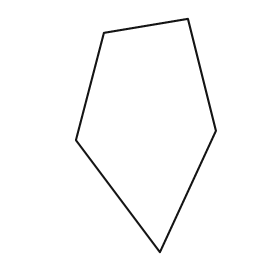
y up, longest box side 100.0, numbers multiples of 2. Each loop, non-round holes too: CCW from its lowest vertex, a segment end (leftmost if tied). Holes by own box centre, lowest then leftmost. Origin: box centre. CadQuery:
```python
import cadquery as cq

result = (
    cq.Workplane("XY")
    .moveTo(6.0, -50.0)
    .lineTo(30.0, 2.0)
    .lineTo(18.0, 50.0)
    .lineTo(-18.0, 44.0)
    .lineTo(-30.0, -2.0)
    .close()
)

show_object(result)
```